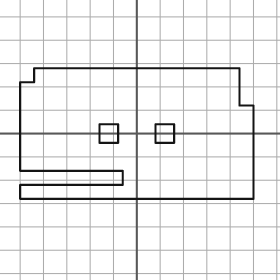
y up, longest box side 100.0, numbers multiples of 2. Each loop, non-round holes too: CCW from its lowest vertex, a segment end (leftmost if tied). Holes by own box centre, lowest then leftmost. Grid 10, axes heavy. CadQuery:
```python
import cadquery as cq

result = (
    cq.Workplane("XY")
    .moveTo(-50.0, -28.0)
    .lineTo(50.0, -28.0)
    .lineTo(50.0, 12.0)
    .lineTo(44.0, 12.0)
    .lineTo(44.0, 28.0)
    .lineTo(-44.0, 28.0)
    .lineTo(-44.0, 22.0)
    .lineTo(-50.0, 22.0)
    .lineTo(-50.0, -16.0)
    .lineTo(-6.0, -16.0)
    .lineTo(-6.0, -22.0)
    .lineTo(-50.0, -22.0)
    .close()
    .moveTo(-16.0, -4.0)
    .lineTo(-8.0, -4.0)
    .lineTo(-8.0, 4.0)
    .lineTo(-16.0, 4.0)
    .close()
    .moveTo(8.0, -4.0)
    .lineTo(16.0, -4.0)
    .lineTo(16.0, 4.0)
    .lineTo(8.0, 4.0)
    .close()
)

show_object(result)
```